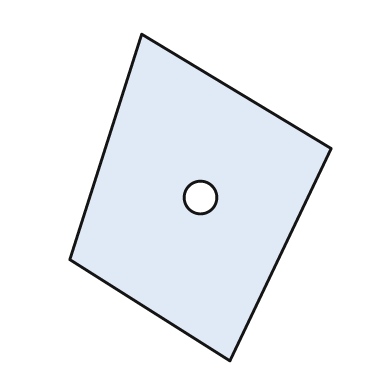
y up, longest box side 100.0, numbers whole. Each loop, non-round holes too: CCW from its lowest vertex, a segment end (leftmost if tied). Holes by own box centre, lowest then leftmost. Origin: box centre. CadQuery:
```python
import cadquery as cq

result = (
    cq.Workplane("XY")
    .moveTo(9.0, -50.0)
    .lineTo(40.0, 15.0)
    .lineTo(-18.0, 50.0)
    .lineTo(-40.0, -19.0)
    .close()
    .moveTo(0.0, 0.0)
    .circle(5.0)
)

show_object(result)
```